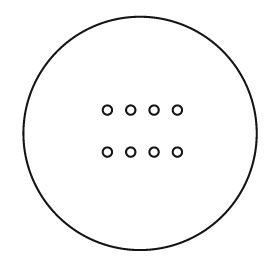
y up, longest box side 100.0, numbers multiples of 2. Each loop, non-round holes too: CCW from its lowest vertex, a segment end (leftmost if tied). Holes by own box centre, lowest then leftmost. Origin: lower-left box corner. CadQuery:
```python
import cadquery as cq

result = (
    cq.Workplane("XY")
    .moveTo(50.0, 50.0)
    .circle(50.0)
    .moveTo(36.0, 42.0)
    .circle(2.0)
    .moveTo(46.0, 42.0)
    .circle(2.0)
    .moveTo(56.0, 42.0)
    .circle(2.0)
    .moveTo(66.0, 42.0)
    .circle(2.0)
    .moveTo(36.0, 60.0)
    .circle(2.0)
    .moveTo(46.0, 60.0)
    .circle(2.0)
    .moveTo(56.0, 60.0)
    .circle(2.0)
    .moveTo(66.0, 60.0)
    .circle(2.0)
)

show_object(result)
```